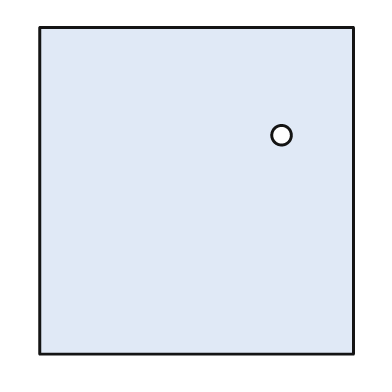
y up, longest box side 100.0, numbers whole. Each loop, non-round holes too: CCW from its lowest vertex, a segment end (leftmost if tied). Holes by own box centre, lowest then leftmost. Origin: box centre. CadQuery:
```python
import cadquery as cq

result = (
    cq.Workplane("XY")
    .moveTo(-48.0, -50.0)
    .lineTo(48.0, -50.0)
    .lineTo(48.0, 50.0)
    .lineTo(-48.0, 50.0)
    .close()
    .moveTo(26.0, 17.0)
    .circle(3.0)
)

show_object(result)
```